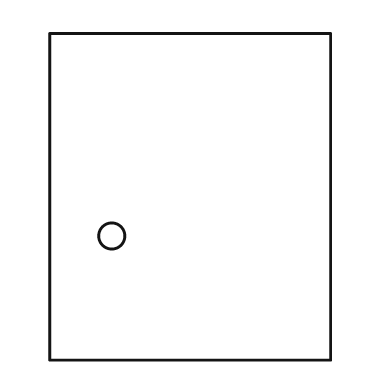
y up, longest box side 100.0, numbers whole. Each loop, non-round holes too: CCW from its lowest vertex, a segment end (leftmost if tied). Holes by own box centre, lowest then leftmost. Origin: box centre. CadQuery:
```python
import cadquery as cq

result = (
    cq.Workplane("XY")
    .moveTo(-43.0, -50.0)
    .lineTo(43.0, -50.0)
    .lineTo(43.0, 50.0)
    .lineTo(-43.0, 50.0)
    .close()
    .moveTo(-24.0, -12.0)
    .circle(4.0)
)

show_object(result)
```